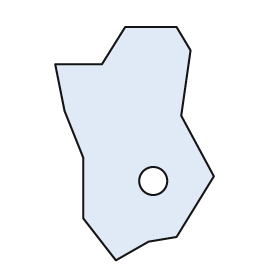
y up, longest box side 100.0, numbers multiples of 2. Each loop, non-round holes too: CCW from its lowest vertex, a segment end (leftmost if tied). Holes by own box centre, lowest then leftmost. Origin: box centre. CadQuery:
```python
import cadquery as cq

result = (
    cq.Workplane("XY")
    .moveTo(-8.0, -50.0)
    .lineTo(6.0, -42.0)
    .lineTo(18.0, -40.0)
    .lineTo(34.0, -14.0)
    .lineTo(20.0, 12.0)
    .lineTo(24.0, 40.0)
    .lineTo(18.0, 50.0)
    .lineTo(-4.0, 50.0)
    .lineTo(-14.0, 34.0)
    .lineTo(-34.0, 34.0)
    .lineTo(-30.0, 14.0)
    .lineTo(-22.0, -6.0)
    .lineTo(-22.0, -32.0)
    .close()
    .moveTo(8.0, -16.0)
    .circle(6.0)
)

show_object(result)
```